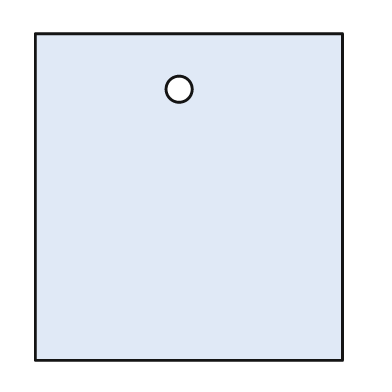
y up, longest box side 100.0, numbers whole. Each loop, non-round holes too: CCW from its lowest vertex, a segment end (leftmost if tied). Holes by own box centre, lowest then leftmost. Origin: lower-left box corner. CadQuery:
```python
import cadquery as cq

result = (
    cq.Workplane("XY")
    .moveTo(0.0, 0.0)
    .lineTo(94.0, 0.0)
    .lineTo(94.0, 100.0)
    .lineTo(0.0, 100.0)
    .close()
    .moveTo(44.0, 83.0)
    .circle(4.0)
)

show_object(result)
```